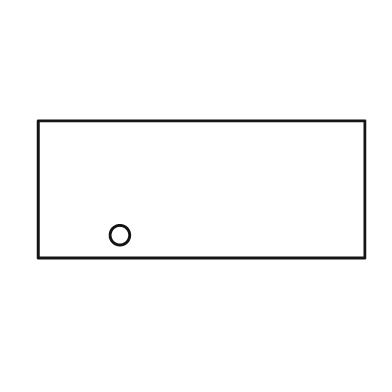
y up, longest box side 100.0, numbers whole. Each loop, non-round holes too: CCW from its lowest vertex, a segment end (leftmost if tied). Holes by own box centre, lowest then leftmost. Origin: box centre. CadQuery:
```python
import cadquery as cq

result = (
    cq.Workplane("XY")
    .moveTo(-50.0, -21.0)
    .lineTo(50.0, -21.0)
    .lineTo(50.0, 21.0)
    .lineTo(-50.0, 21.0)
    .close()
    .moveTo(-25.0, -14.0)
    .circle(3.0)
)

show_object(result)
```